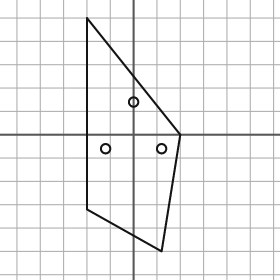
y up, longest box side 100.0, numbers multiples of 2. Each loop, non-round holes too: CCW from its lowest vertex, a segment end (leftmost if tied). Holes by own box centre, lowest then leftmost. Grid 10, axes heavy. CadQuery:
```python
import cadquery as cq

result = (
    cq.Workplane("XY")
    .moveTo(12.0, -50.0)
    .lineTo(20.0, 0.0)
    .lineTo(-20.0, 50.0)
    .lineTo(-20.0, -32.0)
    .close()
    .moveTo(-12.0, -6.0)
    .circle(2.0)
    .moveTo(12.0, -6.0)
    .circle(2.0)
    .moveTo(0.0, 14.0)
    .circle(2.0)
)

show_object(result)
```